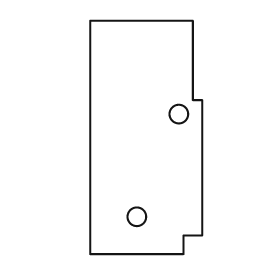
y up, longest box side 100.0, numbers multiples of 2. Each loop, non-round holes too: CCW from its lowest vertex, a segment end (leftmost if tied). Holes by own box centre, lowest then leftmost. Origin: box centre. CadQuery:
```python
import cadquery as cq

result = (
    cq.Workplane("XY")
    .moveTo(-24.0, -50.0)
    .lineTo(16.0, -50.0)
    .lineTo(16.0, -42.0)
    .lineTo(24.0, -42.0)
    .lineTo(24.0, 16.0)
    .lineTo(20.0, 16.0)
    .lineTo(20.0, 50.0)
    .lineTo(-24.0, 50.0)
    .close()
    .moveTo(-4.0, -34.0)
    .circle(4.0)
    .moveTo(14.0, 10.0)
    .circle(4.0)
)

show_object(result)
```